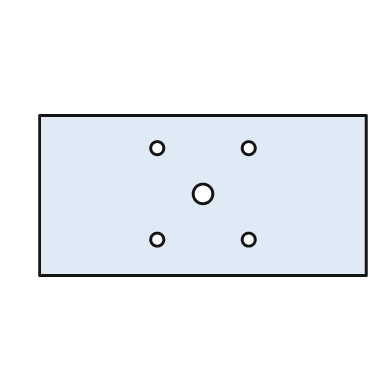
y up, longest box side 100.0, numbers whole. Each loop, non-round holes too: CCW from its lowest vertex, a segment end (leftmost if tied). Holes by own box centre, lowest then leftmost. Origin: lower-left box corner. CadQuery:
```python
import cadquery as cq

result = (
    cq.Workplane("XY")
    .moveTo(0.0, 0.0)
    .lineTo(100.0, 0.0)
    .lineTo(100.0, 49.0)
    .lineTo(0.0, 49.0)
    .close()
    .moveTo(36.0, 11.0)
    .circle(2.0)
    .moveTo(64.0, 11.0)
    .circle(2.0)
    .moveTo(50.0, 25.0)
    .circle(3.0)
    .moveTo(36.0, 39.0)
    .circle(2.0)
    .moveTo(64.0, 39.0)
    .circle(2.0)
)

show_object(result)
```